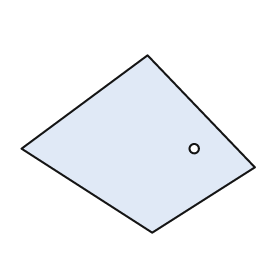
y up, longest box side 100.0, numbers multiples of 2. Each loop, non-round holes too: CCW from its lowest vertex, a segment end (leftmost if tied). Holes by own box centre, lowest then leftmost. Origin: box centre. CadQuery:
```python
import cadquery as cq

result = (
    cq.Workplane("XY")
    .moveTo(6.0, -38.0)
    .lineTo(50.0, -10.0)
    .lineTo(4.0, 38.0)
    .lineTo(-50.0, -2.0)
    .close()
    .moveTo(24.0, -2.0)
    .circle(2.0)
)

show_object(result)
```